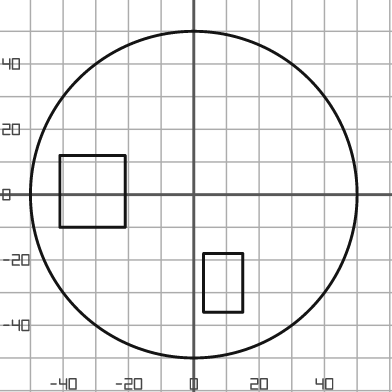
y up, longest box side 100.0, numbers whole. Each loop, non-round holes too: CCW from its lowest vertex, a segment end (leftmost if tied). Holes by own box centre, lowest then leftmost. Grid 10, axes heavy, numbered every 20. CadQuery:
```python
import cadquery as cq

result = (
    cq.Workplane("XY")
    .moveTo(0.0, 0.0)
    .circle(50.0)
    .moveTo(3.0, -36.0)
    .lineTo(15.0, -36.0)
    .lineTo(15.0, -18.0)
    .lineTo(3.0, -18.0)
    .close()
    .moveTo(-41.0, -10.0)
    .lineTo(-21.0, -10.0)
    .lineTo(-21.0, 12.0)
    .lineTo(-41.0, 12.0)
    .close()
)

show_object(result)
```